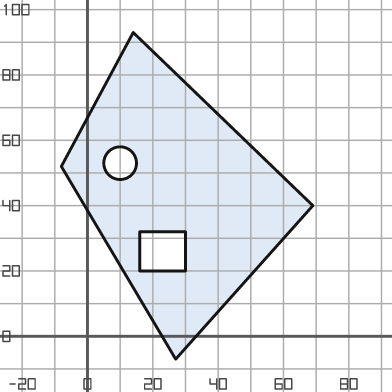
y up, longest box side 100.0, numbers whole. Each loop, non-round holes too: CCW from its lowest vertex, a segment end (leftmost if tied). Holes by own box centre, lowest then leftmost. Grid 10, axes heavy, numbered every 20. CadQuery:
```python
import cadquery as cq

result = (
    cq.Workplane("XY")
    .moveTo(27.0, -7.0)
    .lineTo(69.0, 40.0)
    .lineTo(14.0, 93.0)
    .lineTo(-8.0, 52.0)
    .close()
    .moveTo(16.0, 20.0)
    .lineTo(30.0, 20.0)
    .lineTo(30.0, 32.0)
    .lineTo(16.0, 32.0)
    .close()
    .moveTo(10.0, 53.0)
    .circle(5.0)
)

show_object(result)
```